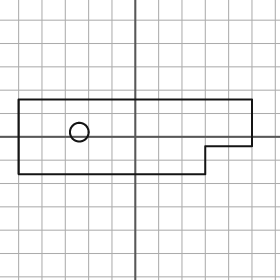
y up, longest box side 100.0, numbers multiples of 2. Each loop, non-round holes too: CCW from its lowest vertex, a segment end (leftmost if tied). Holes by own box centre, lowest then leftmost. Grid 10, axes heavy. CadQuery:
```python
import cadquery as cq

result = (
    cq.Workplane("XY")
    .moveTo(-50.0, -16.0)
    .lineTo(30.0, -16.0)
    .lineTo(30.0, -4.0)
    .lineTo(50.0, -4.0)
    .lineTo(50.0, 16.0)
    .lineTo(-50.0, 16.0)
    .close()
    .moveTo(-24.0, 2.0)
    .circle(4.0)
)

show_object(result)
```